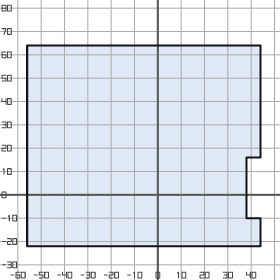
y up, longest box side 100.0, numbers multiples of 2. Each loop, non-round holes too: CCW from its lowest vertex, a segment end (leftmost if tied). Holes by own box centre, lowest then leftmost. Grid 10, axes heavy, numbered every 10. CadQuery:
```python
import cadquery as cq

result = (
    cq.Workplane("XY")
    .moveTo(-56.0, -22.0)
    .lineTo(44.0, -22.0)
    .lineTo(44.0, -10.0)
    .lineTo(38.0, -10.0)
    .lineTo(38.0, 16.0)
    .lineTo(44.0, 16.0)
    .lineTo(44.0, 64.0)
    .lineTo(-56.0, 64.0)
    .close()
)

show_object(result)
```